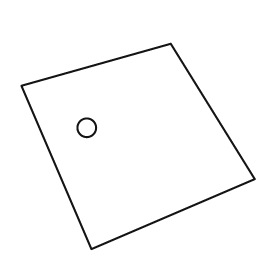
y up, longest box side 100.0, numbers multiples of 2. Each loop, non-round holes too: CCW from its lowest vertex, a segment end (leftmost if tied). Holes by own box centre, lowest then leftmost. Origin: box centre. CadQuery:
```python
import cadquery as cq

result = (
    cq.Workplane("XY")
    .moveTo(-20.0, -44.0)
    .lineTo(50.0, -14.0)
    .lineTo(14.0, 44.0)
    .lineTo(-50.0, 26.0)
    .close()
    .moveTo(-22.0, 8.0)
    .circle(4.0)
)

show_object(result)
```